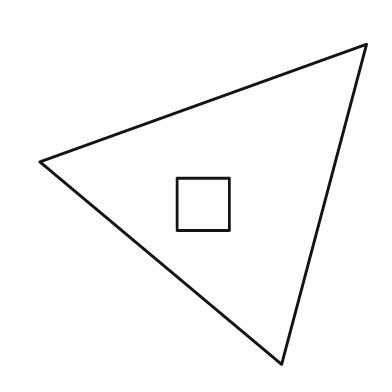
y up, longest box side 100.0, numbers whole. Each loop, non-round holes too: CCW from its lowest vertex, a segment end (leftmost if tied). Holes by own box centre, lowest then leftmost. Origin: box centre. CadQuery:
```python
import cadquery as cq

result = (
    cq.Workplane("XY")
    .moveTo(24.0, -49.0)
    .lineTo(50.0, 49.0)
    .lineTo(-50.0, 13.0)
    .close()
    .moveTo(-8.0, -8.0)
    .lineTo(8.0, -8.0)
    .lineTo(8.0, 8.0)
    .lineTo(-8.0, 8.0)
    .close()
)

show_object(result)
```